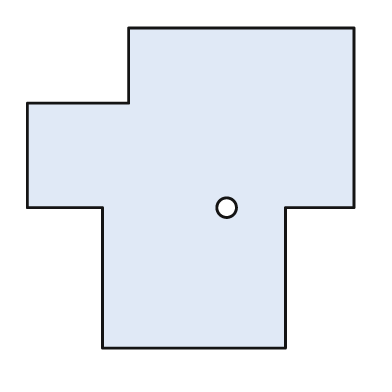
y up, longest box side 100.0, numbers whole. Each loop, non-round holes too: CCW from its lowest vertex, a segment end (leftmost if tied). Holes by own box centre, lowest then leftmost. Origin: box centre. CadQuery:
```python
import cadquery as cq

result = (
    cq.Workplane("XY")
    .moveTo(-27.0, -49.0)
    .lineTo(29.0, -49.0)
    .lineTo(29.0, -6.0)
    .lineTo(50.0, -6.0)
    .lineTo(50.0, 49.0)
    .lineTo(-19.0, 49.0)
    .lineTo(-19.0, 26.0)
    .lineTo(-50.0, 26.0)
    .lineTo(-50.0, -6.0)
    .lineTo(-27.0, -6.0)
    .close()
    .moveTo(11.0, -6.0)
    .circle(3.0)
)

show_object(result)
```